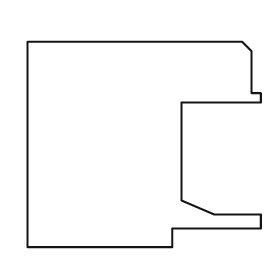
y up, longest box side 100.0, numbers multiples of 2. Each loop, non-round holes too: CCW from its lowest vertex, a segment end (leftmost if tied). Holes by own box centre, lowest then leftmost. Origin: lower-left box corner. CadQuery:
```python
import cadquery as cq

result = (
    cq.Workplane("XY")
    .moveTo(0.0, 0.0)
    .lineTo(62.0, 0.0)
    .lineTo(62.0, 8.0)
    .lineTo(100.0, 8.0)
    .lineTo(100.0, 14.0)
    .lineTo(80.0, 14.0)
    .lineTo(66.0, 20.0)
    .lineTo(66.0, 62.0)
    .lineTo(100.0, 62.0)
    .lineTo(100.0, 66.0)
    .lineTo(96.0, 66.0)
    .lineTo(96.0, 84.0)
    .lineTo(92.0, 88.0)
    .lineTo(0.0, 88.0)
    .close()
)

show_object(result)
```